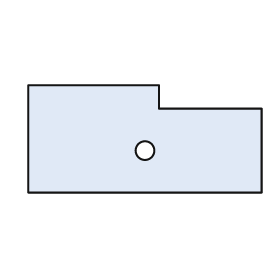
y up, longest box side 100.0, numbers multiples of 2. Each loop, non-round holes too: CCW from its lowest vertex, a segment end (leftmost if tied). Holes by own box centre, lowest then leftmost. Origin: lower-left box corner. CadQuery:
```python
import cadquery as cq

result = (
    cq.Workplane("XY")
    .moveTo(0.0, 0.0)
    .lineTo(100.0, 0.0)
    .lineTo(100.0, 36.0)
    .lineTo(56.0, 36.0)
    .lineTo(56.0, 46.0)
    .lineTo(0.0, 46.0)
    .close()
    .moveTo(50.0, 18.0)
    .circle(4.0)
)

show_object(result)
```